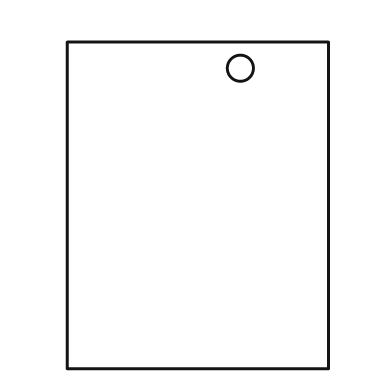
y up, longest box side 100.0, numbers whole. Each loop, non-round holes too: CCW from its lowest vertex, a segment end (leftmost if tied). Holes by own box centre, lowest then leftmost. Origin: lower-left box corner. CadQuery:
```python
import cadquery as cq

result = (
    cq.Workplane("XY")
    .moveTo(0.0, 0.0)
    .lineTo(80.0, 0.0)
    .lineTo(80.0, 100.0)
    .lineTo(0.0, 100.0)
    .close()
    .moveTo(53.0, 92.0)
    .circle(4.0)
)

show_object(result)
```